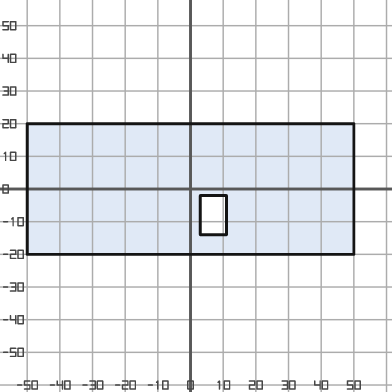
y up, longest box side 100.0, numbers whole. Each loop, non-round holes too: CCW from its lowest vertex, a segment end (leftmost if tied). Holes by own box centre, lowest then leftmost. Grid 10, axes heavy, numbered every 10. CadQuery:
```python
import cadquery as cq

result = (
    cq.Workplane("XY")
    .moveTo(-50.0, -20.0)
    .lineTo(50.0, -20.0)
    .lineTo(50.0, 20.0)
    .lineTo(-50.0, 20.0)
    .close()
    .moveTo(3.0, -14.0)
    .lineTo(11.0, -14.0)
    .lineTo(11.0, -2.0)
    .lineTo(3.0, -2.0)
    .close()
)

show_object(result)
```